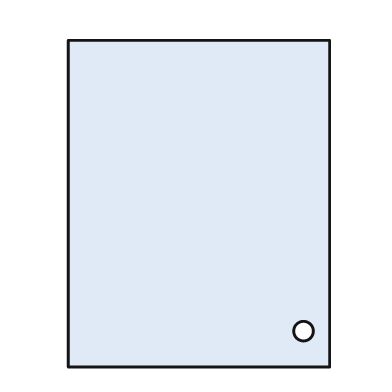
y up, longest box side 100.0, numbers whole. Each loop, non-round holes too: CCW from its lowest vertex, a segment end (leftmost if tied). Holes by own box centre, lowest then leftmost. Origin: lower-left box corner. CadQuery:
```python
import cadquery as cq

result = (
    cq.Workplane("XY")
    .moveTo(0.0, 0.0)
    .lineTo(80.0, 0.0)
    .lineTo(80.0, 100.0)
    .lineTo(0.0, 100.0)
    .close()
    .moveTo(72.0, 11.0)
    .circle(3.0)
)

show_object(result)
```